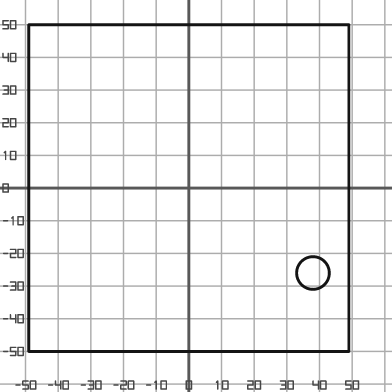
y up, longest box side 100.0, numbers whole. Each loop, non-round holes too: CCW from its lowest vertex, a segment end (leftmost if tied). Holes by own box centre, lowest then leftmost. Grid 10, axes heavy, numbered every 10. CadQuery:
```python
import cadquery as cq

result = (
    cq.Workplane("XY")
    .moveTo(-49.0, -50.0)
    .lineTo(49.0, -50.0)
    .lineTo(49.0, 50.0)
    .lineTo(-49.0, 50.0)
    .close()
    .moveTo(38.0, -26.0)
    .circle(5.0)
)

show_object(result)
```